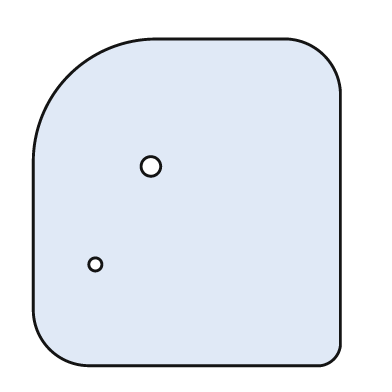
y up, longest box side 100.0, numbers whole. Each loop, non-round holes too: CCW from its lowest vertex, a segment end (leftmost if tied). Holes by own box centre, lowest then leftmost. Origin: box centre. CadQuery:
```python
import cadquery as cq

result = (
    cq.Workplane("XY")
    .moveTo(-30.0, -50.0)
    .lineTo(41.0, -50.0)
    .threePointArc((45.0, -48.0), (47.0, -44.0))
    .lineTo(47.0, 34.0)
    .threePointArc((42.0, 45.0), (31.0, 50.0))
    .lineTo(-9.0, 50.0)
    .threePointArc((-36.0, 39.0), (-47.0, 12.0))
    .lineTo(-47.0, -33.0)
    .threePointArc((-42.0, -45.0), (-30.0, -50.0))
    .close()
    .moveTo(-28.0, -19.0)
    .circle(2.0)
    .moveTo(-11.0, 11.0)
    .circle(3.0)
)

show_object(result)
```